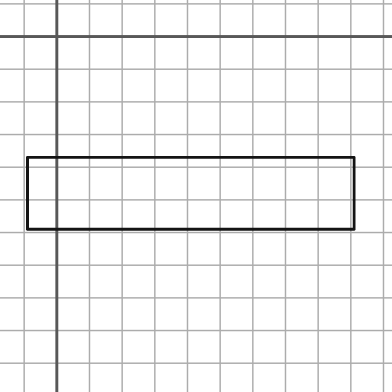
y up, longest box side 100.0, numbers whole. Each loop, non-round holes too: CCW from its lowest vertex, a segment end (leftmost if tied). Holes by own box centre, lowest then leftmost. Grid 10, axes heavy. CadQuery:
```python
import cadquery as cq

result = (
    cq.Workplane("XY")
    .moveTo(-9.0, -59.0)
    .lineTo(91.0, -59.0)
    .lineTo(91.0, -37.0)
    .lineTo(-9.0, -37.0)
    .close()
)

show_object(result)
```